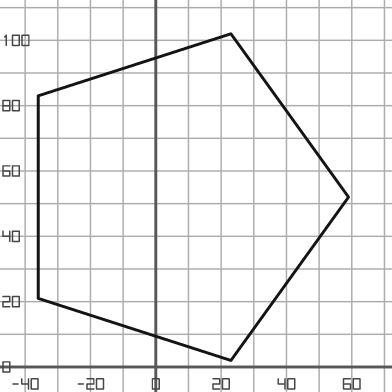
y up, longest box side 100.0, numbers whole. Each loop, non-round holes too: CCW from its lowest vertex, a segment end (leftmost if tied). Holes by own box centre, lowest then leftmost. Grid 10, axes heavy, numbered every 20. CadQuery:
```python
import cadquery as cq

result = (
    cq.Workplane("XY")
    .moveTo(23.0, 2.0)
    .lineTo(59.0, 52.0)
    .lineTo(23.0, 102.0)
    .lineTo(-36.0, 83.0)
    .lineTo(-36.0, 21.0)
    .close()
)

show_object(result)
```